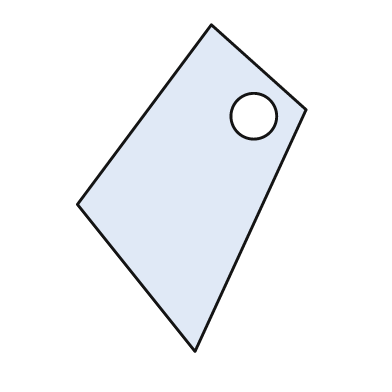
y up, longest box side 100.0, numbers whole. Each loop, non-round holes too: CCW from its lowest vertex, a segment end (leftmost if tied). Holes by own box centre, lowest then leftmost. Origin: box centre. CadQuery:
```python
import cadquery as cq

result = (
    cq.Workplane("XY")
    .moveTo(1.0, -50.0)
    .lineTo(35.0, 24.0)
    .lineTo(6.0, 50.0)
    .lineTo(-35.0, -5.0)
    .close()
    .moveTo(19.0, 22.0)
    .circle(7.0)
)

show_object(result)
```